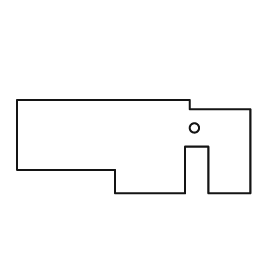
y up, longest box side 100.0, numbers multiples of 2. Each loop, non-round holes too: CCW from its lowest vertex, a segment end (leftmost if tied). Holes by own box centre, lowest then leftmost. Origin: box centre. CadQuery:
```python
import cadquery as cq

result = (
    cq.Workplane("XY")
    .moveTo(-8.0, -20.0)
    .lineTo(22.0, -20.0)
    .lineTo(22.0, 0.0)
    .lineTo(32.0, 0.0)
    .lineTo(32.0, -20.0)
    .lineTo(50.0, -20.0)
    .lineTo(50.0, 16.0)
    .lineTo(24.0, 16.0)
    .lineTo(24.0, 20.0)
    .lineTo(-50.0, 20.0)
    .lineTo(-50.0, -10.0)
    .lineTo(-8.0, -10.0)
    .close()
    .moveTo(26.0, 8.0)
    .circle(2.0)
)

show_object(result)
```